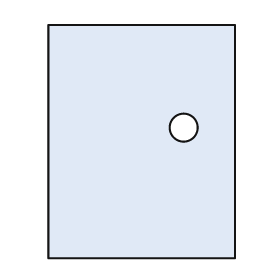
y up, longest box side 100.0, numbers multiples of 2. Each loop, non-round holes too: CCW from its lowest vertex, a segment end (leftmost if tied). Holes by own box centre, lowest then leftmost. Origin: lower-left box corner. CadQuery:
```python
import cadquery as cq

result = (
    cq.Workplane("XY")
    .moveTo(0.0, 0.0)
    .lineTo(80.0, 0.0)
    .lineTo(80.0, 100.0)
    .lineTo(0.0, 100.0)
    .close()
    .moveTo(58.0, 56.0)
    .circle(6.0)
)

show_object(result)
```